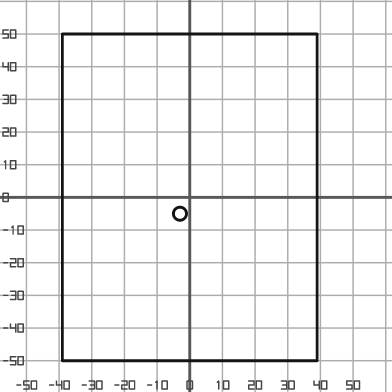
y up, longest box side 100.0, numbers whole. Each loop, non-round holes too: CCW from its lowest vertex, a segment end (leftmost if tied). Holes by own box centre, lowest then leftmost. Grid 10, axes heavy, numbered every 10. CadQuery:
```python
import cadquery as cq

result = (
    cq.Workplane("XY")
    .moveTo(-39.0, -50.0)
    .lineTo(39.0, -50.0)
    .lineTo(39.0, 50.0)
    .lineTo(-39.0, 50.0)
    .close()
    .moveTo(-3.0, -5.0)
    .circle(2.0)
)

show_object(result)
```